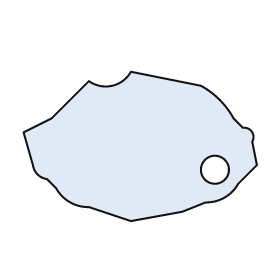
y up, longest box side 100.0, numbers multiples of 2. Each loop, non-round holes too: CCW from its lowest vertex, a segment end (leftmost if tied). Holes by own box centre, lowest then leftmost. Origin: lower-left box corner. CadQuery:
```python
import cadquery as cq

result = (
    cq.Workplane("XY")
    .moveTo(46.0, 0.0)
    .lineTo(68.0, 4.0)
    .lineTo(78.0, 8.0)
    .threePointArc((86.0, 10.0), (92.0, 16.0))
    .lineTo(100.0, 24.0)
    .lineTo(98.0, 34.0)
    .threePointArc((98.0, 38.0), (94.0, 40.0))
    .lineTo(90.0, 44.0)
    .threePointArc((84.0, 52.0), (76.0, 58.0))
    .lineTo(46.0, 64.0)
    .threePointArc((38.0, 58.0), (28.0, 60.0))
    .lineTo(12.0, 44.0)
    .lineTo(0.0, 38.0)
    .lineTo(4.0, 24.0)
    .threePointArc((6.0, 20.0), (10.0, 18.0))
    .lineTo(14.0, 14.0)
    .threePointArc((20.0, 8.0), (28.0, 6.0))
    .close()
    .moveTo(82.0, 22.0)
    .circle(6.0)
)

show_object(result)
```